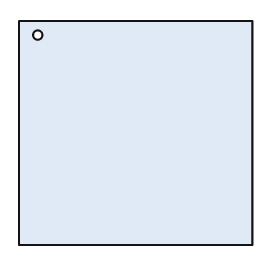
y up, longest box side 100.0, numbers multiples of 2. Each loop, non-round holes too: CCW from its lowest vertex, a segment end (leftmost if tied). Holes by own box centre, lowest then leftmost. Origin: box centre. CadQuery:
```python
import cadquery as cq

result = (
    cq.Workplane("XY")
    .moveTo(-50.0, -48.0)
    .lineTo(50.0, -48.0)
    .lineTo(50.0, 48.0)
    .lineTo(-50.0, 48.0)
    .close()
    .moveTo(-42.0, 42.0)
    .circle(2.0)
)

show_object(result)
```